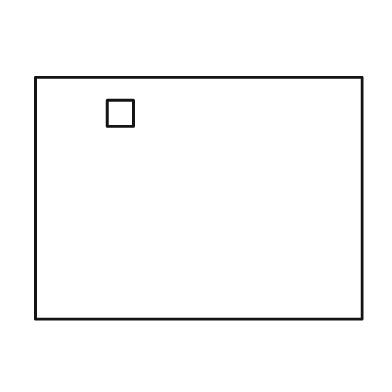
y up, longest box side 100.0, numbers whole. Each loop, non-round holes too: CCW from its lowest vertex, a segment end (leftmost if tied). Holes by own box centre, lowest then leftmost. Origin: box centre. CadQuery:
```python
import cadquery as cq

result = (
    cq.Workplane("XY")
    .moveTo(-50.0, -37.0)
    .lineTo(50.0, -37.0)
    .lineTo(50.0, 37.0)
    .lineTo(-50.0, 37.0)
    .close()
    .moveTo(-28.0, 22.0)
    .lineTo(-20.0, 22.0)
    .lineTo(-20.0, 30.0)
    .lineTo(-28.0, 30.0)
    .close()
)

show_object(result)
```